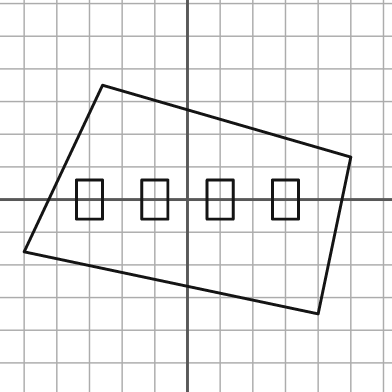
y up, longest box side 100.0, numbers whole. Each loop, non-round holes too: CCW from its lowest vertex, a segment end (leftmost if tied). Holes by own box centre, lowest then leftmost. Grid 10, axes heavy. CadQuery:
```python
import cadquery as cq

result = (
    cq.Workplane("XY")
    .moveTo(40.0, -35.0)
    .lineTo(50.0, 13.0)
    .lineTo(-26.0, 35.0)
    .lineTo(-50.0, -16.0)
    .close()
    .moveTo(-34.0, -6.0)
    .lineTo(-26.0, -6.0)
    .lineTo(-26.0, 6.0)
    .lineTo(-34.0, 6.0)
    .close()
    .moveTo(-14.0, -6.0)
    .lineTo(-6.0, -6.0)
    .lineTo(-6.0, 6.0)
    .lineTo(-14.0, 6.0)
    .close()
    .moveTo(6.0, -6.0)
    .lineTo(14.0, -6.0)
    .lineTo(14.0, 6.0)
    .lineTo(6.0, 6.0)
    .close()
    .moveTo(26.0, -6.0)
    .lineTo(34.0, -6.0)
    .lineTo(34.0, 6.0)
    .lineTo(26.0, 6.0)
    .close()
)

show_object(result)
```